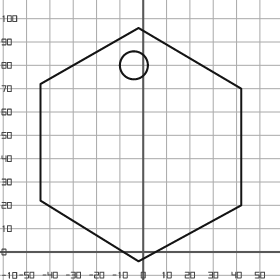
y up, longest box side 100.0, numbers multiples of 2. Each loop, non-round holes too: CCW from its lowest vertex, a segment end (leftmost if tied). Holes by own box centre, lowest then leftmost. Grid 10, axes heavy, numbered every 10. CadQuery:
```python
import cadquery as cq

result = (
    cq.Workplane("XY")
    .moveTo(-2.0, -4.0)
    .lineTo(42.0, 20.0)
    .lineTo(42.0, 70.0)
    .lineTo(-2.0, 96.0)
    .lineTo(-44.0, 72.0)
    .lineTo(-44.0, 22.0)
    .close()
    .moveTo(-4.0, 80.0)
    .circle(6.0)
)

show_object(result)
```